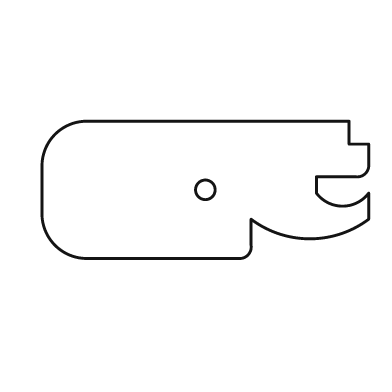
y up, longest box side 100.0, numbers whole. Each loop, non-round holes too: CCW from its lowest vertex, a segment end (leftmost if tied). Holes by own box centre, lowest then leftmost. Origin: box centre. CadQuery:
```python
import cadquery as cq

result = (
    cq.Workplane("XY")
    .moveTo(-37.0, -21.0)
    .lineTo(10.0, -21.0)
    .threePointArc((13.0, -20.0), (14.0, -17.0))
    .lineTo(14.0, -9.0)
    .threePointArc((32.0, -15.0), (50.0, -9.0))
    .lineTo(50.0, -1.0)
    .threePointArc((42.0, -5.0), (34.0, -1.0))
    .lineTo(34.0, 4.0)
    .lineTo(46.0, 4.0)
    .threePointArc((49.0, 5.0), (50.0, 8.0))
    .lineTo(50.0, 14.0)
    .lineTo(44.0, 14.0)
    .lineTo(44.0, 21.0)
    .lineTo(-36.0, 21.0)
    .threePointArc((-46.0, 17.0), (-50.0, 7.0))
    .lineTo(-50.0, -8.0)
    .threePointArc((-46.0, -17.0), (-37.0, -21.0))
    .close()
    .moveTo(0.0, 0.0)
    .circle(3.0)
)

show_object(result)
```